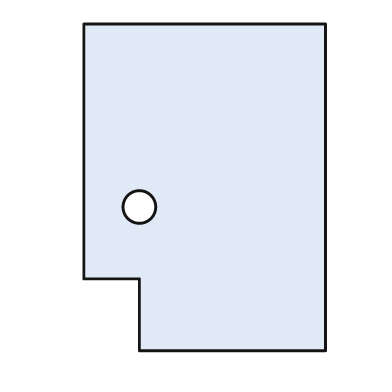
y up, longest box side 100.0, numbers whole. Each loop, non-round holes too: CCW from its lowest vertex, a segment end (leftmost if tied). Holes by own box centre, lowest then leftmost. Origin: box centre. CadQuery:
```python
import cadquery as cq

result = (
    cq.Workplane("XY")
    .moveTo(-20.0, -50.0)
    .lineTo(37.0, -50.0)
    .lineTo(37.0, 50.0)
    .lineTo(-37.0, 50.0)
    .lineTo(-37.0, -28.0)
    .lineTo(-20.0, -28.0)
    .close()
    .moveTo(-20.0, -6.0)
    .circle(5.0)
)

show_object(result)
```